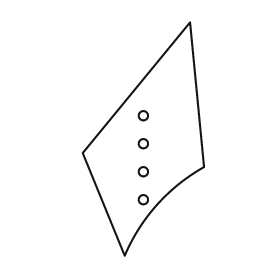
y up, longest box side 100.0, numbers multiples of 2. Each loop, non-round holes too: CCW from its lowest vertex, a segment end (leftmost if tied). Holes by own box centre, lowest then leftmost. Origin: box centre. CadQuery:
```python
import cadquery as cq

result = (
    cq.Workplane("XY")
    .moveTo(-8.0, -50.0)
    .threePointArc((6.0, -28.0), (26.0, -12.0))
    .lineTo(20.0, 50.0)
    .lineTo(-26.0, -6.0)
    .close()
    .moveTo(0.0, -26.0)
    .circle(2.0)
    .moveTo(0.0, -14.0)
    .circle(2.0)
    .moveTo(0.0, -2.0)
    .circle(2.0)
    .moveTo(0.0, 10.0)
    .circle(2.0)
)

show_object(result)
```